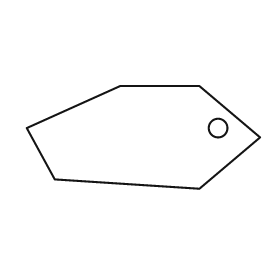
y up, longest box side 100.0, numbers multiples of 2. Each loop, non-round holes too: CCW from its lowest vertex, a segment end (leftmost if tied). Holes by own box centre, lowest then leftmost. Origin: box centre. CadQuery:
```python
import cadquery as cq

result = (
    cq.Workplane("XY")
    .moveTo(24.0, -22.0)
    .lineTo(50.0, 0.0)
    .lineTo(24.0, 22.0)
    .lineTo(-10.0, 22.0)
    .lineTo(-50.0, 4.0)
    .lineTo(-38.0, -18.0)
    .close()
    .moveTo(32.0, 4.0)
    .circle(4.0)
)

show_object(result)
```